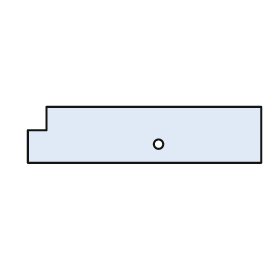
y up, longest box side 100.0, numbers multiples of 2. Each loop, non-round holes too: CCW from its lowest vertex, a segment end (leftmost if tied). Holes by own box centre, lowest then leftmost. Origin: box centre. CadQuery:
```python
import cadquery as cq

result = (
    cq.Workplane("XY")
    .moveTo(-50.0, -12.0)
    .lineTo(50.0, -12.0)
    .lineTo(50.0, 12.0)
    .lineTo(-42.0, 12.0)
    .lineTo(-42.0, 2.0)
    .lineTo(-50.0, 2.0)
    .close()
    .moveTo(6.0, -4.0)
    .circle(2.0)
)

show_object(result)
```